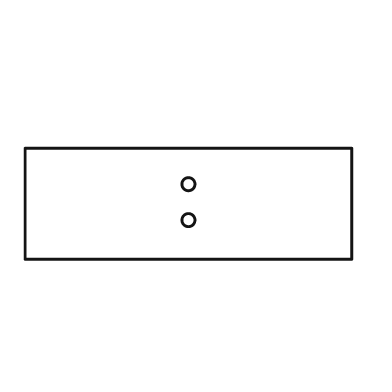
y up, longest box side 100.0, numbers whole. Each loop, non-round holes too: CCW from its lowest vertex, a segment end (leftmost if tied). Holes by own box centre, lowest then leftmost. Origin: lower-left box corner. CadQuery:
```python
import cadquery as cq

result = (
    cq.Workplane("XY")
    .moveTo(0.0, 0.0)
    .lineTo(100.0, 0.0)
    .lineTo(100.0, 34.0)
    .lineTo(0.0, 34.0)
    .close()
    .moveTo(50.0, 12.0)
    .circle(2.0)
    .moveTo(50.0, 23.0)
    .circle(2.0)
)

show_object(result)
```